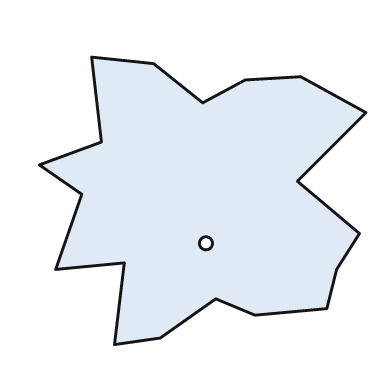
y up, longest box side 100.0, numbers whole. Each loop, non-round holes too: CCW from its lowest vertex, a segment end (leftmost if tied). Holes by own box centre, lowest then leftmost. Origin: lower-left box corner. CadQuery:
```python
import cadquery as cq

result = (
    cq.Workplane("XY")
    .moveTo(23.0, 0.0)
    .lineTo(37.0, 2.0)
    .lineTo(54.0, 14.0)
    .lineTo(66.0, 9.0)
    .lineTo(88.0, 11.0)
    .lineTo(91.0, 23.0)
    .lineTo(98.0, 34.0)
    .lineTo(79.0, 50.0)
    .lineTo(100.0, 71.0)
    .lineTo(80.0, 82.0)
    .lineTo(63.0, 81.0)
    .lineTo(50.0, 74.0)
    .lineTo(35.0, 86.0)
    .lineTo(16.0, 88.0)
    .lineTo(19.0, 62.0)
    .lineTo(0.0, 55.0)
    .lineTo(13.0, 46.0)
    .lineTo(5.0, 23.0)
    .lineTo(26.0, 25.0)
    .close()
    .moveTo(51.0, 31.0)
    .circle(2.0)
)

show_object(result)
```